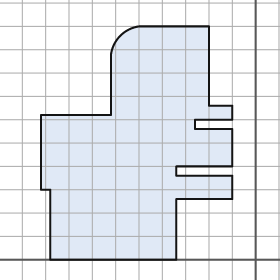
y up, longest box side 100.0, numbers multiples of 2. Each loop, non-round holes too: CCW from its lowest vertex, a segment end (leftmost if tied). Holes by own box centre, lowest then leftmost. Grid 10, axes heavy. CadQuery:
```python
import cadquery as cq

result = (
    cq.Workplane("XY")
    .moveTo(-88.0, 0.0)
    .lineTo(-34.0, 0.0)
    .lineTo(-34.0, 26.0)
    .lineTo(-10.0, 26.0)
    .lineTo(-10.0, 36.0)
    .lineTo(-34.0, 36.0)
    .lineTo(-34.0, 40.0)
    .lineTo(-10.0, 40.0)
    .lineTo(-10.0, 56.0)
    .lineTo(-26.0, 56.0)
    .lineTo(-26.0, 60.0)
    .lineTo(-10.0, 60.0)
    .lineTo(-10.0, 66.0)
    .lineTo(-20.0, 66.0)
    .lineTo(-20.0, 100.0)
    .lineTo(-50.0, 100.0)
    .threePointArc((-58.0, 96.0), (-62.0, 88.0))
    .lineTo(-62.0, 62.0)
    .lineTo(-92.0, 62.0)
    .lineTo(-92.0, 30.0)
    .lineTo(-88.0, 30.0)
    .close()
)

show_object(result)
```